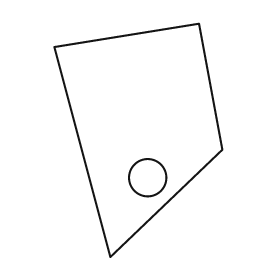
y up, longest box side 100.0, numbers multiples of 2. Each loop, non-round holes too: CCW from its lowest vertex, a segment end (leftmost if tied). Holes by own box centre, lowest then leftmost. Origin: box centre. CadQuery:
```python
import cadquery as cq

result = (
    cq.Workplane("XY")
    .moveTo(-12.0, -50.0)
    .lineTo(36.0, -4.0)
    .lineTo(26.0, 50.0)
    .lineTo(-36.0, 40.0)
    .close()
    .moveTo(4.0, -16.0)
    .circle(8.0)
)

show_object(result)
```